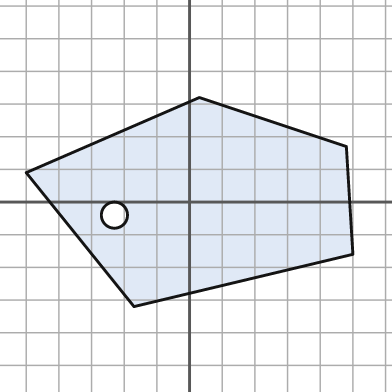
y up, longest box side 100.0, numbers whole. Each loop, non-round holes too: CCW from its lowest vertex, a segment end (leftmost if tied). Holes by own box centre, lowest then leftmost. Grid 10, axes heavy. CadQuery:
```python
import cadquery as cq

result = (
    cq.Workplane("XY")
    .moveTo(-17.0, -32.0)
    .lineTo(50.0, -16.0)
    .lineTo(48.0, 17.0)
    .lineTo(3.0, 32.0)
    .lineTo(-50.0, 9.0)
    .close()
    .moveTo(-23.0, -4.0)
    .circle(4.0)
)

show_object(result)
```